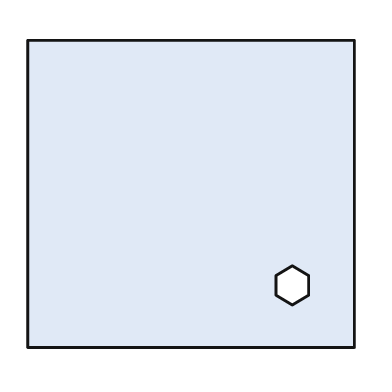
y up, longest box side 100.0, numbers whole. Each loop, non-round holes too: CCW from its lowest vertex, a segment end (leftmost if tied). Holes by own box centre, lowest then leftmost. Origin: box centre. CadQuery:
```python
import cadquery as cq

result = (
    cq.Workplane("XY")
    .moveTo(-50.0, -47.0)
    .lineTo(50.0, -47.0)
    .lineTo(50.0, 47.0)
    .lineTo(-50.0, 47.0)
    .close()
    .moveTo(31.0, -34.0)
    .lineTo(36.0, -31.0)
    .lineTo(36.0, -25.0)
    .lineTo(31.0, -22.0)
    .lineTo(26.0, -25.0)
    .lineTo(26.0, -31.0)
    .close()
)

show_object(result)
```